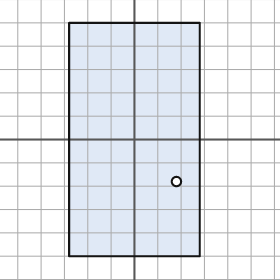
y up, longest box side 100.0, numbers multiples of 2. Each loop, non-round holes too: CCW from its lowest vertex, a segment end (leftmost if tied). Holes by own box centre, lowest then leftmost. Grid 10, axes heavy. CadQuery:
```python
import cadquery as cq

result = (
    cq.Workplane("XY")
    .moveTo(-28.0, -50.0)
    .lineTo(28.0, -50.0)
    .lineTo(28.0, 50.0)
    .lineTo(-28.0, 50.0)
    .close()
    .moveTo(18.0, -18.0)
    .circle(2.0)
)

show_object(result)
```